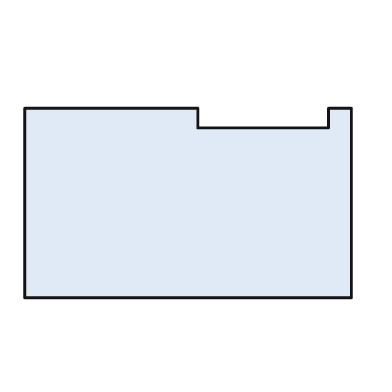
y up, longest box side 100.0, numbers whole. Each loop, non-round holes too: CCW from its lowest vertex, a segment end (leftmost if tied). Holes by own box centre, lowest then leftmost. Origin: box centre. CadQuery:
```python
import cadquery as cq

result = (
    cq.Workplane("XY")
    .moveTo(-50.0, -29.0)
    .lineTo(50.0, -29.0)
    .lineTo(50.0, 29.0)
    .lineTo(43.0, 29.0)
    .lineTo(43.0, 23.0)
    .lineTo(3.0, 23.0)
    .lineTo(3.0, 29.0)
    .lineTo(-50.0, 29.0)
    .close()
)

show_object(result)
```